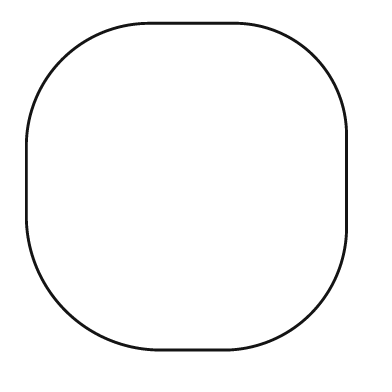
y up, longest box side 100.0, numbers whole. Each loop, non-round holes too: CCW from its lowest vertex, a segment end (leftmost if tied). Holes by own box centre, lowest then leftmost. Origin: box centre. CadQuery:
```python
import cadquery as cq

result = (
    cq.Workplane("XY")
    .moveTo(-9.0, -50.0)
    .lineTo(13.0, -50.0)
    .threePointArc((38.0, -39.0), (49.0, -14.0))
    .lineTo(49.0, 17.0)
    .threePointArc((39.0, 40.0), (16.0, 50.0))
    .lineTo(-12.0, 50.0)
    .threePointArc((-38.0, 39.0), (-49.0, 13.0))
    .lineTo(-49.0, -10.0)
    .threePointArc((-37.0, -38.0), (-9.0, -50.0))
    .close()
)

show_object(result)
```